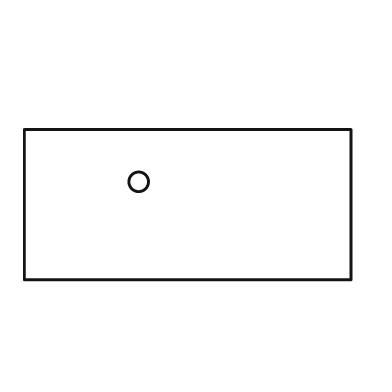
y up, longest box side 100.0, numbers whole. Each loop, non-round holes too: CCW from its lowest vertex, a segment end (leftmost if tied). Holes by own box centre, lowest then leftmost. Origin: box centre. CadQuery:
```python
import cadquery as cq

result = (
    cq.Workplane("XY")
    .moveTo(-50.0, -23.0)
    .lineTo(50.0, -23.0)
    .lineTo(50.0, 23.0)
    .lineTo(-50.0, 23.0)
    .close()
    .moveTo(-15.0, 7.0)
    .circle(3.0)
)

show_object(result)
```